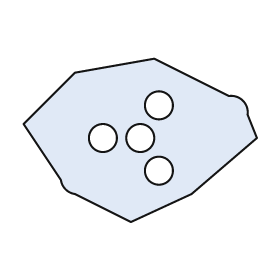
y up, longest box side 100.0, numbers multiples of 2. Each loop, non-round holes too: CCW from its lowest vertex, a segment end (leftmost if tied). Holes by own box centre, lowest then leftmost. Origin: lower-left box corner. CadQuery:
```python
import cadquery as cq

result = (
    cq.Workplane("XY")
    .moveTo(46.0, 0.0)
    .lineTo(72.0, 12.0)
    .lineTo(100.0, 36.0)
    .lineTo(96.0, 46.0)
    .threePointArc((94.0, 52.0), (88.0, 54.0))
    .lineTo(56.0, 70.0)
    .lineTo(22.0, 64.0)
    .lineTo(0.0, 42.0)
    .lineTo(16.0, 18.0)
    .threePointArc((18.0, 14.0), (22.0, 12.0))
    .close()
    .moveTo(58.0, 22.0)
    .circle(6.0)
    .moveTo(34.0, 36.0)
    .circle(6.0)
    .moveTo(50.0, 36.0)
    .circle(6.0)
    .moveTo(58.0, 50.0)
    .circle(6.0)
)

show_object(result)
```